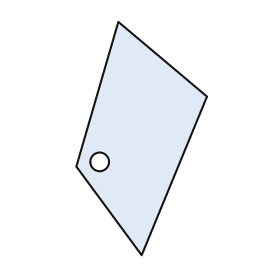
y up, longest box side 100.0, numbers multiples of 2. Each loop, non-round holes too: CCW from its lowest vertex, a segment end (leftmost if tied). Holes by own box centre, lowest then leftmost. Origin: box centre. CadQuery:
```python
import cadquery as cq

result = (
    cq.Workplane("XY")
    .moveTo(0.0, -50.0)
    .lineTo(28.0, 18.0)
    .lineTo(-10.0, 50.0)
    .lineTo(-28.0, -12.0)
    .close()
    .moveTo(-18.0, -10.0)
    .circle(4.0)
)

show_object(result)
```